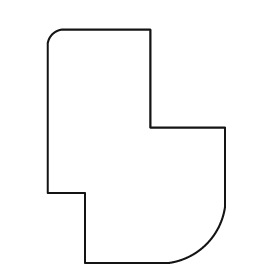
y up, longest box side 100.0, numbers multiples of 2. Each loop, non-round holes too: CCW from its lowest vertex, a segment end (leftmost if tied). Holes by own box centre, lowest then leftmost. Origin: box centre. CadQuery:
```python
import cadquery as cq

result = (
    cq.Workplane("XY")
    .moveTo(-22.0, -50.0)
    .lineTo(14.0, -50.0)
    .threePointArc((30.0, -42.0), (38.0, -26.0))
    .lineTo(38.0, 8.0)
    .lineTo(6.0, 8.0)
    .lineTo(6.0, 50.0)
    .lineTo(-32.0, 50.0)
    .threePointArc((-36.0, 48.0), (-38.0, 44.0))
    .lineTo(-38.0, -20.0)
    .lineTo(-22.0, -20.0)
    .close()
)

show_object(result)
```